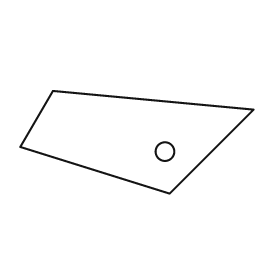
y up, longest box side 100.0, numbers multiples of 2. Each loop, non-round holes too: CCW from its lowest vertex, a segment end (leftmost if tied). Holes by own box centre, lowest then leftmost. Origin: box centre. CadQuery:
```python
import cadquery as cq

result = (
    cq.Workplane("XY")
    .moveTo(14.0, -22.0)
    .lineTo(50.0, 14.0)
    .lineTo(-36.0, 22.0)
    .lineTo(-50.0, -2.0)
    .close()
    .moveTo(12.0, -4.0)
    .circle(4.0)
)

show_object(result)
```